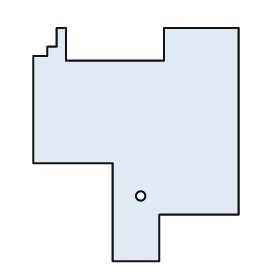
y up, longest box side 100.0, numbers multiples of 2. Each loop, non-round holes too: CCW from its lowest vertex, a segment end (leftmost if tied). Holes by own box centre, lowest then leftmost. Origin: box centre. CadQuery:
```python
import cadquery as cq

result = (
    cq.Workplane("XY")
    .moveTo(-10.0, -50.0)
    .lineTo(10.0, -50.0)
    .lineTo(10.0, -30.0)
    .lineTo(44.0, -30.0)
    .lineTo(44.0, 50.0)
    .lineTo(12.0, 50.0)
    .lineTo(12.0, 36.0)
    .lineTo(-30.0, 36.0)
    .lineTo(-30.0, 50.0)
    .lineTo(-34.0, 50.0)
    .lineTo(-34.0, 42.0)
    .lineTo(-38.0, 42.0)
    .lineTo(-38.0, 38.0)
    .lineTo(-44.0, 38.0)
    .lineTo(-44.0, -8.0)
    .lineTo(-10.0, -8.0)
    .close()
    .moveTo(2.0, -22.0)
    .circle(2.0)
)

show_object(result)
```